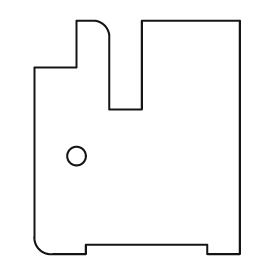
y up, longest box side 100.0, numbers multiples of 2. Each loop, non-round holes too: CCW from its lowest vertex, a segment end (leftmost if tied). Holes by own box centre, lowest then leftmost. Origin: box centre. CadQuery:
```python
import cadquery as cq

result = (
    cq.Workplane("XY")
    .moveTo(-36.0, -50.0)
    .lineTo(-22.0, -50.0)
    .lineTo(-22.0, -46.0)
    .lineTo(30.0, -46.0)
    .lineTo(30.0, -50.0)
    .lineTo(44.0, -50.0)
    .lineTo(44.0, 50.0)
    .lineTo(2.0, 50.0)
    .lineTo(2.0, 12.0)
    .lineTo(-12.0, 12.0)
    .lineTo(-12.0, 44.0)
    .threePointArc((-14.0, 48.0), (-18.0, 50.0))
    .lineTo(-26.0, 50.0)
    .lineTo(-26.0, 30.0)
    .lineTo(-44.0, 30.0)
    .lineTo(-44.0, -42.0)
    .threePointArc((-42.0, -48.0), (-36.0, -50.0))
    .close()
    .moveTo(-26.0, -8.0)
    .circle(4.0)
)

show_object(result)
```